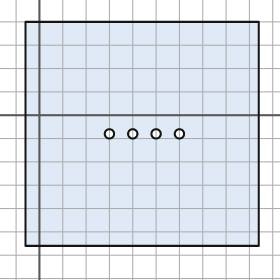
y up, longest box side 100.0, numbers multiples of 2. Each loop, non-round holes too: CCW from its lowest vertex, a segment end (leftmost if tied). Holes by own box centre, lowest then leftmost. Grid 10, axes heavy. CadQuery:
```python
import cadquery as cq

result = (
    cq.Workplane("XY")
    .moveTo(-6.0, -56.0)
    .lineTo(94.0, -56.0)
    .lineTo(94.0, 40.0)
    .lineTo(-6.0, 40.0)
    .close()
    .moveTo(30.0, -8.0)
    .circle(2.0)
    .moveTo(40.0, -8.0)
    .circle(2.0)
    .moveTo(50.0, -8.0)
    .circle(2.0)
    .moveTo(60.0, -8.0)
    .circle(2.0)
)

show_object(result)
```